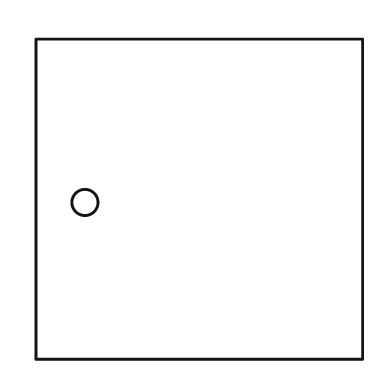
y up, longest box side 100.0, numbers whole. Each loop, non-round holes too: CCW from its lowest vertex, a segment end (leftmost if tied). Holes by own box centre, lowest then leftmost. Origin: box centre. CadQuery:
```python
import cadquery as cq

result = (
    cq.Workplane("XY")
    .moveTo(-50.0, -49.0)
    .lineTo(50.0, -49.0)
    .lineTo(50.0, 49.0)
    .lineTo(-50.0, 49.0)
    .close()
    .moveTo(-35.0, -1.0)
    .circle(4.0)
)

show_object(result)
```